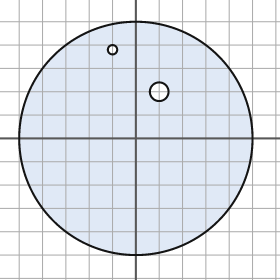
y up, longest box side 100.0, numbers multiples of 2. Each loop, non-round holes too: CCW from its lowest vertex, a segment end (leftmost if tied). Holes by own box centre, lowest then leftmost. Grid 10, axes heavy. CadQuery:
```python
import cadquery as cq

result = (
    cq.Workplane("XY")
    .moveTo(0.0, 0.0)
    .circle(50.0)
    .moveTo(10.0, 20.0)
    .circle(4.0)
    .moveTo(-10.0, 38.0)
    .circle(2.0)
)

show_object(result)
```